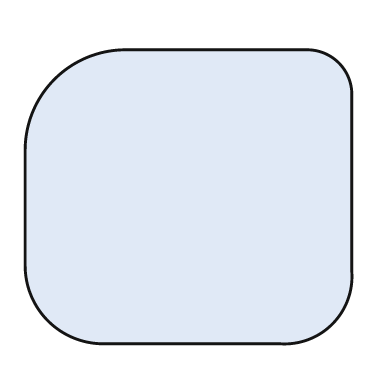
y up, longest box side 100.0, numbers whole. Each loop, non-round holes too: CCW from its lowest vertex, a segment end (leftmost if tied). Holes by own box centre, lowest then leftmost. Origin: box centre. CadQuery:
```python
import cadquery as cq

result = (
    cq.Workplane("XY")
    .moveTo(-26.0, -45.0)
    .lineTo(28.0, -45.0)
    .threePointArc((44.0, -39.0), (50.0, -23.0))
    .lineTo(50.0, 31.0)
    .threePointArc((46.0, 41.0), (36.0, 45.0))
    .lineTo(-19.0, 45.0)
    .threePointArc((-41.0, 36.0), (-50.0, 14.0))
    .lineTo(-50.0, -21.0)
    .threePointArc((-43.0, -38.0), (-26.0, -45.0))
    .close()
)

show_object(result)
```